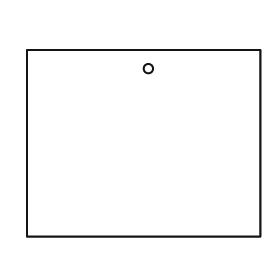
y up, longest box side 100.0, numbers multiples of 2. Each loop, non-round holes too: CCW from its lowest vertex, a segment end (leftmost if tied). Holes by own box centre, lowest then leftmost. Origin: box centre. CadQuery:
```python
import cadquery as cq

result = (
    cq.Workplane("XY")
    .moveTo(-50.0, -40.0)
    .lineTo(50.0, -40.0)
    .lineTo(50.0, 40.0)
    .lineTo(-50.0, 40.0)
    .close()
    .moveTo(2.0, 32.0)
    .circle(2.0)
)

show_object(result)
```